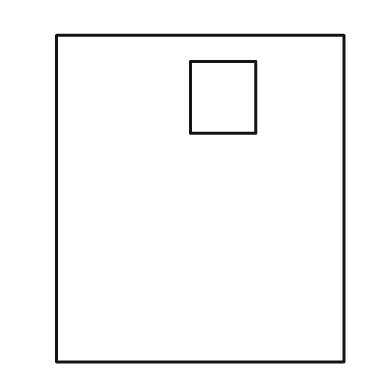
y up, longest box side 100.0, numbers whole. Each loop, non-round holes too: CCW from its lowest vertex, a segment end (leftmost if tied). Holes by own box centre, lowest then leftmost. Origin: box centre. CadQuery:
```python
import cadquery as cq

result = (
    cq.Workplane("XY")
    .moveTo(-44.0, -50.0)
    .lineTo(44.0, -50.0)
    .lineTo(44.0, 50.0)
    .lineTo(-44.0, 50.0)
    .close()
    .moveTo(-3.0, 20.0)
    .lineTo(17.0, 20.0)
    .lineTo(17.0, 42.0)
    .lineTo(-3.0, 42.0)
    .close()
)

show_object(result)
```